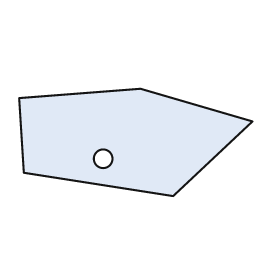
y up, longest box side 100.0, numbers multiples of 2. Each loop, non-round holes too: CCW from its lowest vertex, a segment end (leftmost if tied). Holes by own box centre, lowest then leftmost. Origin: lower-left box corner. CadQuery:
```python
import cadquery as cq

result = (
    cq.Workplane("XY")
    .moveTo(66.0, 0.0)
    .lineTo(100.0, 32.0)
    .lineTo(52.0, 46.0)
    .lineTo(0.0, 42.0)
    .lineTo(2.0, 10.0)
    .close()
    .moveTo(36.0, 16.0)
    .circle(4.0)
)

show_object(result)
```